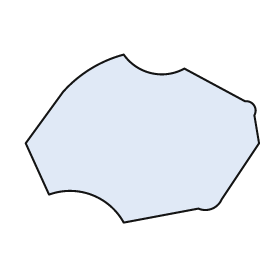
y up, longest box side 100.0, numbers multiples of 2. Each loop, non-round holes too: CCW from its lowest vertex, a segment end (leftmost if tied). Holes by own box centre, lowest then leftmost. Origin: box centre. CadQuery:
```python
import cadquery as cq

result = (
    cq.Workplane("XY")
    .moveTo(-8.0, -36.0)
    .lineTo(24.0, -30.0)
    .threePointArc((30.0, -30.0), (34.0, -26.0))
    .lineTo(50.0, -2.0)
    .lineTo(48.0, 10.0)
    .threePointArc((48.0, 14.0), (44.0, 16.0))
    .lineTo(18.0, 30.0)
    .threePointArc((4.0, 28.0), (-8.0, 36.0))
    .threePointArc((-22.0, 30.0), (-34.0, 20.0))
    .lineTo(-50.0, -2.0)
    .lineTo(-40.0, -24.0)
    .threePointArc((-22.0, -24.0), (-8.0, -36.0))
    .close()
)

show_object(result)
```